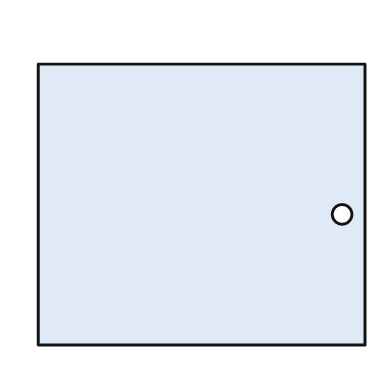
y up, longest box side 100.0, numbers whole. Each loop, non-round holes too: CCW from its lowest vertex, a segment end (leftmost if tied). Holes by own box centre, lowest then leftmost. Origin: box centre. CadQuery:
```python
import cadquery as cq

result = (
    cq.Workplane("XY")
    .moveTo(-50.0, -43.0)
    .lineTo(50.0, -43.0)
    .lineTo(50.0, 43.0)
    .lineTo(-50.0, 43.0)
    .close()
    .moveTo(43.0, -3.0)
    .circle(3.0)
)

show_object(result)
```